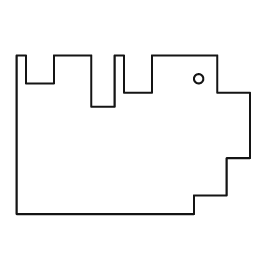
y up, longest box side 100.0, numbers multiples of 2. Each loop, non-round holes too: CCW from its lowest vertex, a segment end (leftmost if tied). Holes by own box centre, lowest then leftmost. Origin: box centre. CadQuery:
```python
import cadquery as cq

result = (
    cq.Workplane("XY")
    .moveTo(-50.0, -34.0)
    .lineTo(26.0, -34.0)
    .lineTo(26.0, -26.0)
    .lineTo(40.0, -26.0)
    .lineTo(40.0, -10.0)
    .lineTo(50.0, -10.0)
    .lineTo(50.0, 18.0)
    .lineTo(36.0, 18.0)
    .lineTo(36.0, 34.0)
    .lineTo(8.0, 34.0)
    .lineTo(8.0, 18.0)
    .lineTo(-4.0, 18.0)
    .lineTo(-4.0, 34.0)
    .lineTo(-8.0, 34.0)
    .lineTo(-8.0, 12.0)
    .lineTo(-18.0, 12.0)
    .lineTo(-18.0, 34.0)
    .lineTo(-34.0, 34.0)
    .lineTo(-34.0, 22.0)
    .lineTo(-46.0, 22.0)
    .lineTo(-46.0, 34.0)
    .lineTo(-50.0, 34.0)
    .close()
    .moveTo(28.0, 24.0)
    .circle(2.0)
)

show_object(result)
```